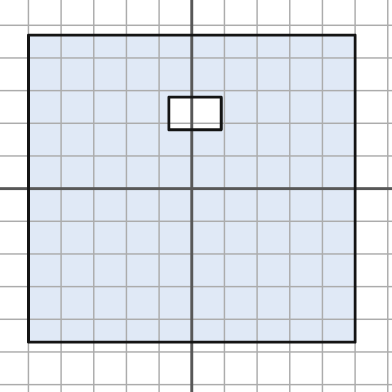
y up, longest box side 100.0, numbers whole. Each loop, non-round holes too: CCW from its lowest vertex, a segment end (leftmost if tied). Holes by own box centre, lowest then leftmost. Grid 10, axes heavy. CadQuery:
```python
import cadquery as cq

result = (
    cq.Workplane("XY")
    .moveTo(-50.0, -47.0)
    .lineTo(50.0, -47.0)
    .lineTo(50.0, 47.0)
    .lineTo(-50.0, 47.0)
    .close()
    .moveTo(-7.0, 18.0)
    .lineTo(9.0, 18.0)
    .lineTo(9.0, 28.0)
    .lineTo(-7.0, 28.0)
    .close()
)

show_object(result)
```